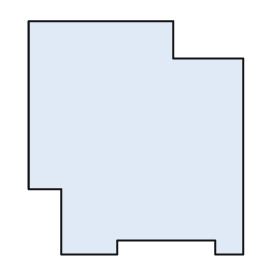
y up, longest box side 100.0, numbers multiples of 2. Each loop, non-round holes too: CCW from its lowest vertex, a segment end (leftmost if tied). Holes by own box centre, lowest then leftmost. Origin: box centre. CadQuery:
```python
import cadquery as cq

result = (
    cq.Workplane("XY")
    .moveTo(-32.0, -50.0)
    .lineTo(-8.0, -50.0)
    .lineTo(-8.0, -44.0)
    .lineTo(34.0, -44.0)
    .lineTo(34.0, -50.0)
    .lineTo(46.0, -50.0)
    .lineTo(46.0, 34.0)
    .lineTo(16.0, 34.0)
    .lineTo(16.0, 50.0)
    .lineTo(-46.0, 50.0)
    .lineTo(-46.0, -22.0)
    .lineTo(-32.0, -22.0)
    .close()
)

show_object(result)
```